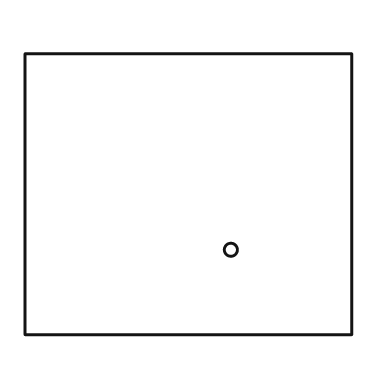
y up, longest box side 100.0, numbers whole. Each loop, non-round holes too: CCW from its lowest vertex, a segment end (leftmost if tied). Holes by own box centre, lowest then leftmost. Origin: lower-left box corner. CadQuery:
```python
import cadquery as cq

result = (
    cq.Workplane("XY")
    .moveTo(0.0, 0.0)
    .lineTo(100.0, 0.0)
    .lineTo(100.0, 86.0)
    .lineTo(0.0, 86.0)
    .close()
    .moveTo(63.0, 26.0)
    .circle(2.0)
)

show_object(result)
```